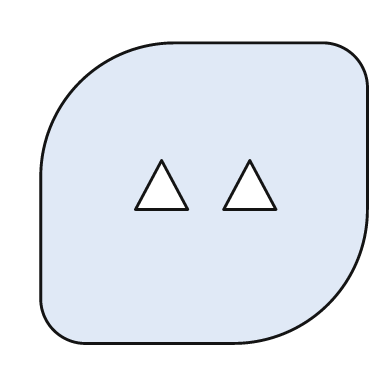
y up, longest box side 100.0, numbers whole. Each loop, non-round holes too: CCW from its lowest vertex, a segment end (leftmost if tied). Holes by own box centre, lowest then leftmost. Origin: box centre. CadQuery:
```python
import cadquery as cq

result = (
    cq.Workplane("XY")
    .moveTo(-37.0, -46.0)
    .lineTo(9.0, -46.0)
    .threePointArc((38.0, -34.0), (50.0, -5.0))
    .lineTo(50.0, 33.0)
    .threePointArc((46.0, 42.0), (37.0, 46.0))
    .lineTo(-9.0, 46.0)
    .threePointArc((-38.0, 34.0), (-50.0, 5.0))
    .lineTo(-50.0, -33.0)
    .threePointArc((-46.0, -42.0), (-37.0, -46.0))
    .close()
    .moveTo(-21.0, -5.0)
    .lineTo(-5.0, -5.0)
    .lineTo(-13.0, 10.0)
    .close()
    .moveTo(6.0, -5.0)
    .lineTo(22.0, -5.0)
    .lineTo(14.0, 10.0)
    .close()
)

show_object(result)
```